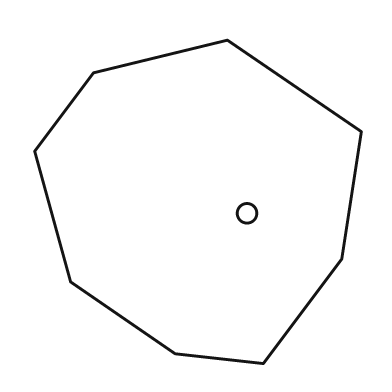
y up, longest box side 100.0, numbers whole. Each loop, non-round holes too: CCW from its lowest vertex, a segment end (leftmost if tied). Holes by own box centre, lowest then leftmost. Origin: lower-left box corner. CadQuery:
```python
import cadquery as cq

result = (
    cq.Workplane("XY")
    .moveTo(70.0, 0.0)
    .lineTo(94.0, 32.0)
    .lineTo(100.0, 71.0)
    .lineTo(59.0, 99.0)
    .lineTo(18.0, 89.0)
    .lineTo(0.0, 65.0)
    .lineTo(11.0, 25.0)
    .lineTo(43.0, 3.0)
    .close()
    .moveTo(65.0, 46.0)
    .circle(3.0)
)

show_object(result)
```